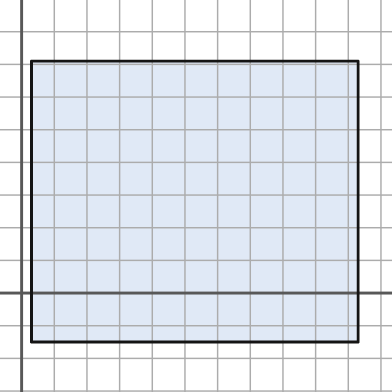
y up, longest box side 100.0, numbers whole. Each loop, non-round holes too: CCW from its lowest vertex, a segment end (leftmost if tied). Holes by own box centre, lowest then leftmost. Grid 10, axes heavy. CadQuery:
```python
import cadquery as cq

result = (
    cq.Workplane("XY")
    .moveTo(3.0, -15.0)
    .lineTo(103.0, -15.0)
    .lineTo(103.0, 71.0)
    .lineTo(3.0, 71.0)
    .close()
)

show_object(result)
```